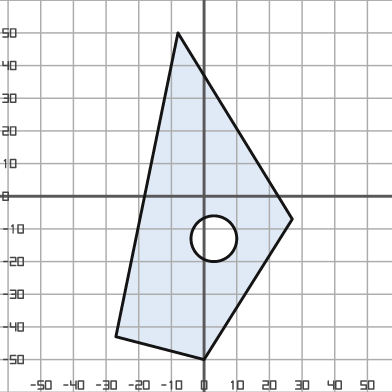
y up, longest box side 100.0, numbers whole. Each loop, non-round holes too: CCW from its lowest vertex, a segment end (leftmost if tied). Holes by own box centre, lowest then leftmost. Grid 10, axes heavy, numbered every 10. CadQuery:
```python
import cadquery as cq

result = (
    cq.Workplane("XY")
    .moveTo(0.0, -50.0)
    .lineTo(27.0, -7.0)
    .lineTo(-8.0, 50.0)
    .lineTo(-27.0, -43.0)
    .close()
    .moveTo(3.0, -13.0)
    .circle(7.0)
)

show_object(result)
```